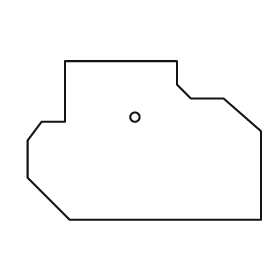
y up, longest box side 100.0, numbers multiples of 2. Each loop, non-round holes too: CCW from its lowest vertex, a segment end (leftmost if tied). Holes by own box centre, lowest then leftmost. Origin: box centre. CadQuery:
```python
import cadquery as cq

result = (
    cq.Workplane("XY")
    .moveTo(-32.0, -34.0)
    .lineTo(50.0, -34.0)
    .lineTo(50.0, 4.0)
    .lineTo(34.0, 18.0)
    .lineTo(20.0, 18.0)
    .lineTo(14.0, 24.0)
    .lineTo(14.0, 34.0)
    .lineTo(-34.0, 34.0)
    .lineTo(-34.0, 8.0)
    .lineTo(-44.0, 8.0)
    .lineTo(-50.0, 0.0)
    .lineTo(-50.0, -16.0)
    .close()
    .moveTo(-4.0, 10.0)
    .circle(2.0)
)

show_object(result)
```